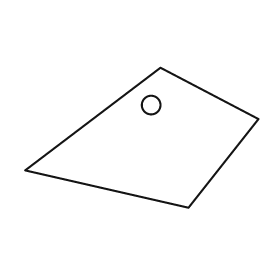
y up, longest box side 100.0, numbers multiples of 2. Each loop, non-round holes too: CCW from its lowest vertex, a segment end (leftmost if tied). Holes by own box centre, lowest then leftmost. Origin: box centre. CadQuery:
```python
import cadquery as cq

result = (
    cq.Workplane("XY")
    .moveTo(20.0, -30.0)
    .lineTo(50.0, 8.0)
    .lineTo(8.0, 30.0)
    .lineTo(-50.0, -14.0)
    .close()
    .moveTo(4.0, 14.0)
    .circle(4.0)
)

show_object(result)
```